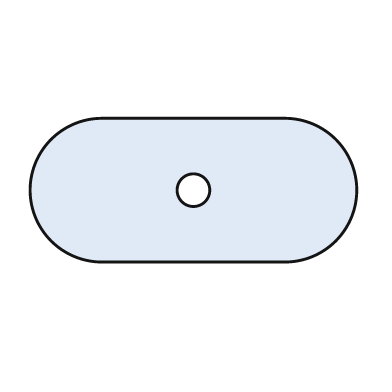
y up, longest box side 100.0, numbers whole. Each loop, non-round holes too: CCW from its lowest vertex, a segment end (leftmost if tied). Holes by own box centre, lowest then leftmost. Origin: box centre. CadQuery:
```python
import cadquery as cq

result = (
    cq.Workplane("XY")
    .moveTo(-28.0, -22.0)
    .lineTo(28.0, -22.0)
    .threePointArc((50.0, 0.0), (28.0, 22.0))
    .lineTo(-28.0, 22.0)
    .threePointArc((-50.0, 0.0), (-28.0, -22.0))
    .close()
    .moveTo(0.0, 0.0)
    .circle(5.0)
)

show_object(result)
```